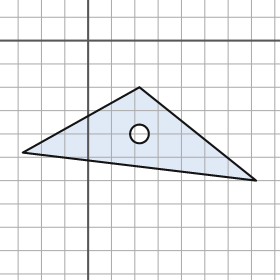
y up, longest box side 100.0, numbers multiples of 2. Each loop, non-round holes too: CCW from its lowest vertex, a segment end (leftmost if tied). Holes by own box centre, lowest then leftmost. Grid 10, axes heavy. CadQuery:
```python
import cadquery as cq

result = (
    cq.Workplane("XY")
    .moveTo(72.0, -60.0)
    .lineTo(22.0, -20.0)
    .lineTo(-28.0, -48.0)
    .close()
    .moveTo(22.0, -40.0)
    .circle(4.0)
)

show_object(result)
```